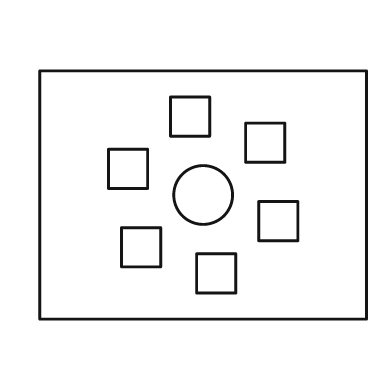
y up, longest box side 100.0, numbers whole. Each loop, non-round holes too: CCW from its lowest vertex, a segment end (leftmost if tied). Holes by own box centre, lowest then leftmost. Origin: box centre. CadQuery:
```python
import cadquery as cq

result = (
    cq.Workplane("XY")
    .moveTo(-50.0, -38.0)
    .lineTo(50.0, -38.0)
    .lineTo(50.0, 38.0)
    .lineTo(-50.0, 38.0)
    .close()
    .moveTo(-2.0, -30.0)
    .lineTo(10.0, -30.0)
    .lineTo(10.0, -18.0)
    .lineTo(-2.0, -18.0)
    .close()
    .moveTo(-25.0, -22.0)
    .lineTo(-13.0, -22.0)
    .lineTo(-13.0, -10.0)
    .lineTo(-25.0, -10.0)
    .close()
    .moveTo(17.0, -14.0)
    .lineTo(29.0, -14.0)
    .lineTo(29.0, -2.0)
    .lineTo(17.0, -2.0)
    .close()
    .moveTo(0.0, 0.0)
    .circle(9.0)
    .moveTo(-29.0, 2.0)
    .lineTo(-17.0, 2.0)
    .lineTo(-17.0, 14.0)
    .lineTo(-29.0, 14.0)
    .close()
    .moveTo(13.0, 10.0)
    .lineTo(25.0, 10.0)
    .lineTo(25.0, 22.0)
    .lineTo(13.0, 22.0)
    .close()
    .moveTo(-10.0, 18.0)
    .lineTo(2.0, 18.0)
    .lineTo(2.0, 30.0)
    .lineTo(-10.0, 30.0)
    .close()
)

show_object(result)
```